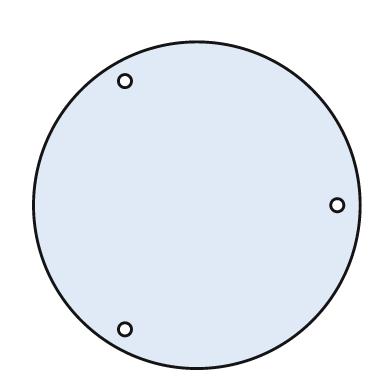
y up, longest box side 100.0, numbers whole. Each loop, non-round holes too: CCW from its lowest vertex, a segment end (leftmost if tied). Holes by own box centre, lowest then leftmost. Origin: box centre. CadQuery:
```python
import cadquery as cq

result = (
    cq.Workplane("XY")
    .moveTo(0.0, 0.0)
    .circle(50.0)
    .moveTo(-22.0, -38.0)
    .circle(2.0)
    .moveTo(43.0, 0.0)
    .circle(2.0)
    .moveTo(-22.0, 38.0)
    .circle(2.0)
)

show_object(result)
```